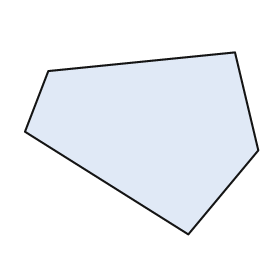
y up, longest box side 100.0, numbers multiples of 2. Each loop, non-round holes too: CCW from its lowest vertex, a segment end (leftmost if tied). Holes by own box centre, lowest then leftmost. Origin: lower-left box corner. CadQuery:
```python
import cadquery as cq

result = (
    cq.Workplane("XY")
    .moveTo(70.0, 0.0)
    .lineTo(100.0, 36.0)
    .lineTo(90.0, 78.0)
    .lineTo(10.0, 70.0)
    .lineTo(0.0, 44.0)
    .close()
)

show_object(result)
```